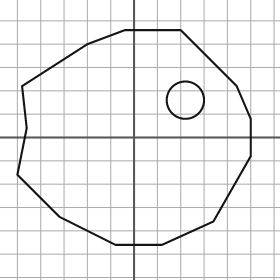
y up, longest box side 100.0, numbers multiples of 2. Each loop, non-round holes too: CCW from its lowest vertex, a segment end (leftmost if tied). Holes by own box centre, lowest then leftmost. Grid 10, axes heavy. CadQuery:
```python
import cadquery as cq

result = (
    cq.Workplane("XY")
    .moveTo(-8.0, -46.0)
    .lineTo(12.0, -46.0)
    .lineTo(34.0, -36.0)
    .lineTo(50.0, -8.0)
    .lineTo(50.0, 8.0)
    .lineTo(44.0, 22.0)
    .lineTo(20.0, 46.0)
    .lineTo(-4.0, 46.0)
    .lineTo(-20.0, 40.0)
    .lineTo(-48.0, 22.0)
    .lineTo(-46.0, 4.0)
    .lineTo(-50.0, -16.0)
    .lineTo(-32.0, -34.0)
    .close()
    .moveTo(22.0, 16.0)
    .circle(8.0)
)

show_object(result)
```